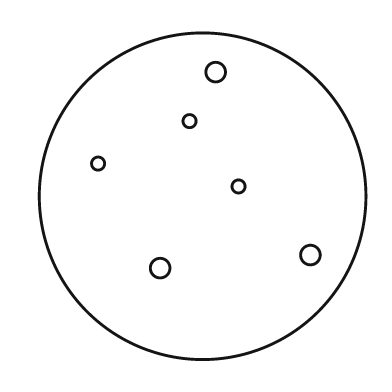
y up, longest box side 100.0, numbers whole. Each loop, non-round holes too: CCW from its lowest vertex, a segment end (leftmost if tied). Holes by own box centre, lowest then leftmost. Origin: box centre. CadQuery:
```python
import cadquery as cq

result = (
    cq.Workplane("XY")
    .moveTo(0.0, 0.0)
    .circle(50.0)
    .moveTo(-13.0, -22.0)
    .circle(3.0)
    .moveTo(33.0, -18.0)
    .circle(3.0)
    .moveTo(11.0, 3.0)
    .circle(2.0)
    .moveTo(-32.0, 10.0)
    .circle(2.0)
    .moveTo(-4.0, 23.0)
    .circle(2.0)
    .moveTo(4.0, 38.0)
    .circle(3.0)
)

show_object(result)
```